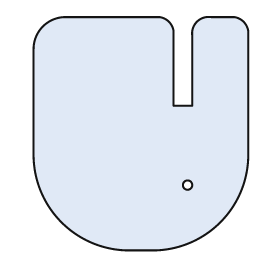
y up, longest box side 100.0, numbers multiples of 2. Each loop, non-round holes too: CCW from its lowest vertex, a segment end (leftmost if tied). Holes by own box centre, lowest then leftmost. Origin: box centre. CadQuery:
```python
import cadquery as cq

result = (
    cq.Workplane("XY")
    .moveTo(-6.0, -50.0)
    .lineTo(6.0, -50.0)
    .threePointArc((34.0, -38.0), (46.0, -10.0))
    .lineTo(46.0, 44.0)
    .threePointArc((44.0, 48.0), (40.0, 50.0))
    .lineTo(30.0, 50.0)
    .threePointArc((24.0, 48.0), (22.0, 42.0))
    .lineTo(22.0, 12.0)
    .lineTo(14.0, 12.0)
    .lineTo(14.0, 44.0)
    .threePointArc((12.0, 48.0), (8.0, 50.0))
    .lineTo(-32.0, 50.0)
    .threePointArc((-42.0, 46.0), (-46.0, 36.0))
    .lineTo(-46.0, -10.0)
    .threePointArc((-34.0, -38.0), (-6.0, -50.0))
    .close()
    .moveTo(20.0, -22.0)
    .circle(2.0)
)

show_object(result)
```